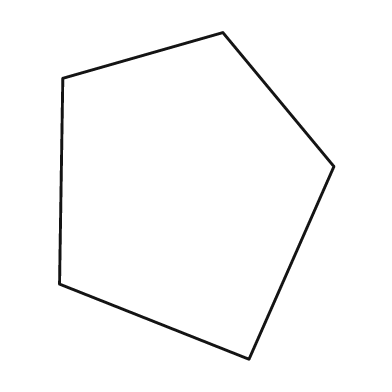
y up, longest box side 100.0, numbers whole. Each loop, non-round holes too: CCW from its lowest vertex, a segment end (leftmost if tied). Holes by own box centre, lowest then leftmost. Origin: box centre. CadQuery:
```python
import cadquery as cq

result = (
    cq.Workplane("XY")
    .moveTo(16.0, -50.0)
    .lineTo(42.0, 9.0)
    .lineTo(8.0, 50.0)
    .lineTo(-41.0, 36.0)
    .lineTo(-42.0, -27.0)
    .close()
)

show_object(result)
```